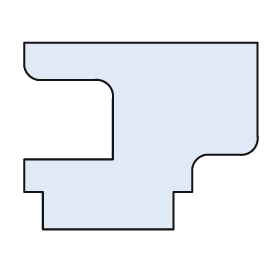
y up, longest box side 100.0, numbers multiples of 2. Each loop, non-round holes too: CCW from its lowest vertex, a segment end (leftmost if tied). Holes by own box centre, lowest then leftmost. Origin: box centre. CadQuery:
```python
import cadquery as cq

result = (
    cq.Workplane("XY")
    .moveTo(-42.0, -40.0)
    .lineTo(14.0, -40.0)
    .lineTo(14.0, -24.0)
    .lineTo(22.0, -24.0)
    .lineTo(22.0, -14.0)
    .threePointArc((24.0, -10.0), (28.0, -8.0))
    .lineTo(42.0, -8.0)
    .threePointArc((48.0, -6.0), (50.0, 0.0))
    .lineTo(50.0, 40.0)
    .lineTo(-50.0, 40.0)
    .lineTo(-50.0, 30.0)
    .threePointArc((-48.0, 26.0), (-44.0, 24.0))
    .lineTo(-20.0, 24.0)
    .threePointArc((-14.0, 22.0), (-12.0, 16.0))
    .lineTo(-12.0, -10.0)
    .lineTo(-50.0, -10.0)
    .lineTo(-50.0, -24.0)
    .lineTo(-42.0, -24.0)
    .close()
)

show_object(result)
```